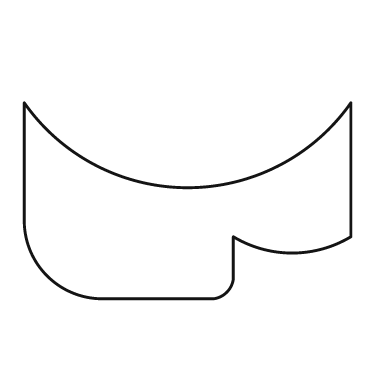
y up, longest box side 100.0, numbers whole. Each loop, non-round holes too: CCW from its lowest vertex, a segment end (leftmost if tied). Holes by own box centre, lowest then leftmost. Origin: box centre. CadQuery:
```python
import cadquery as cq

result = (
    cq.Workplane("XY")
    .moveTo(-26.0, -30.0)
    .lineTo(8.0, -30.0)
    .threePointArc((12.0, -28.0), (14.0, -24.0))
    .lineTo(14.0, -11.0)
    .threePointArc((32.0, -16.0), (50.0, -11.0))
    .lineTo(50.0, 30.0)
    .threePointArc((0.0, 4.0), (-50.0, 30.0))
    .lineTo(-50.0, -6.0)
    .threePointArc((-43.0, -23.0), (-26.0, -30.0))
    .close()
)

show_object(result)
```